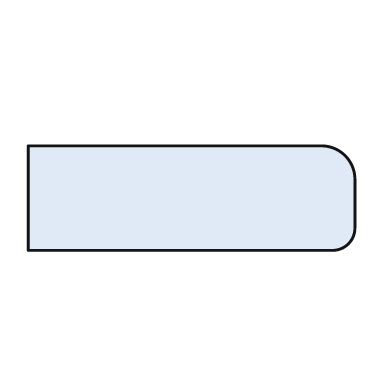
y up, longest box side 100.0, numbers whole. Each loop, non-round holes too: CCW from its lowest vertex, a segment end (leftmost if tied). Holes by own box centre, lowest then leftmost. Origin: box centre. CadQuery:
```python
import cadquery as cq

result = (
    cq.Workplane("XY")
    .moveTo(-50.0, -16.0)
    .lineTo(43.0, -16.0)
    .threePointArc((48.0, -14.0), (50.0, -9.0))
    .lineTo(50.0, 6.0)
    .threePointArc((47.0, 13.0), (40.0, 16.0))
    .lineTo(-50.0, 16.0)
    .close()
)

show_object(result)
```